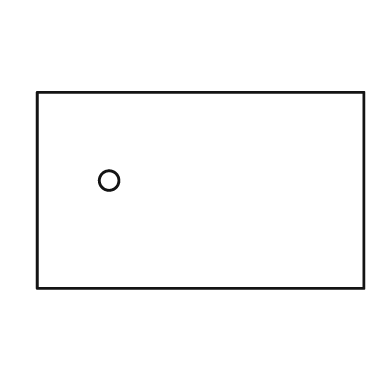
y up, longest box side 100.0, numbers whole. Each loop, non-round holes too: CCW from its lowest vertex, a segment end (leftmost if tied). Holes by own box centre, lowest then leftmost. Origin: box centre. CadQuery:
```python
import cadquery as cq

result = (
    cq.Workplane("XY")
    .moveTo(-50.0, -30.0)
    .lineTo(50.0, -30.0)
    .lineTo(50.0, 30.0)
    .lineTo(-50.0, 30.0)
    .close()
    .moveTo(-28.0, 3.0)
    .circle(3.0)
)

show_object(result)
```